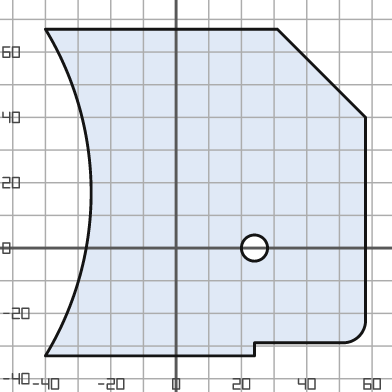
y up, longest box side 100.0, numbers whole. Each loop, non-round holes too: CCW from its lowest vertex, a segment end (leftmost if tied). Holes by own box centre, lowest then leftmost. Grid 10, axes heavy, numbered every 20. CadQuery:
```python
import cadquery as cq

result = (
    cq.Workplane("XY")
    .moveTo(-40.0, -33.0)
    .lineTo(24.0, -33.0)
    .lineTo(24.0, -29.0)
    .lineTo(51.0, -29.0)
    .threePointArc((56.0, -27.0), (58.0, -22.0))
    .lineTo(58.0, 40.0)
    .lineTo(31.0, 67.0)
    .lineTo(-40.0, 67.0)
    .threePointArc((-26.0, 17.0), (-40.0, -33.0))
    .close()
    .moveTo(24.0, 0.0)
    .circle(4.0)
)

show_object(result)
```